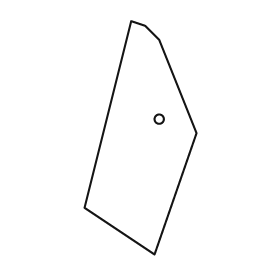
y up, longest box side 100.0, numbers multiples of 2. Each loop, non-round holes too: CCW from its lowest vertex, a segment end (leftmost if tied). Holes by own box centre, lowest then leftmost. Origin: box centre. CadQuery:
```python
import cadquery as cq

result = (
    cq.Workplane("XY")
    .moveTo(6.0, -50.0)
    .lineTo(24.0, 2.0)
    .lineTo(8.0, 42.0)
    .lineTo(2.0, 48.0)
    .lineTo(-4.0, 50.0)
    .lineTo(-24.0, -30.0)
    .close()
    .moveTo(8.0, 8.0)
    .circle(2.0)
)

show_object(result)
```